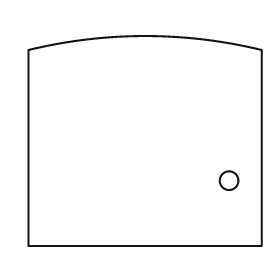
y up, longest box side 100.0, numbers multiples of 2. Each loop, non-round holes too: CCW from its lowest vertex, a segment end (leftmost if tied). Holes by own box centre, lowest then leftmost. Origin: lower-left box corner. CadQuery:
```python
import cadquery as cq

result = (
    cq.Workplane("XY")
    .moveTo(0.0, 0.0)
    .lineTo(100.0, 0.0)
    .lineTo(100.0, 84.0)
    .threePointArc((50.0, 90.0), (0.0, 84.0))
    .close()
    .moveTo(86.0, 28.0)
    .circle(4.0)
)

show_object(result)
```